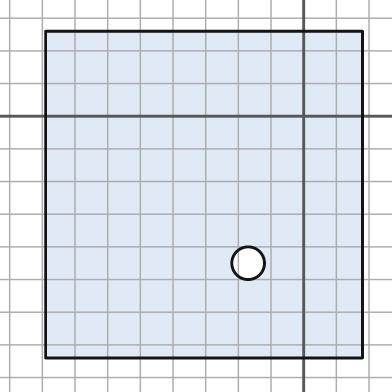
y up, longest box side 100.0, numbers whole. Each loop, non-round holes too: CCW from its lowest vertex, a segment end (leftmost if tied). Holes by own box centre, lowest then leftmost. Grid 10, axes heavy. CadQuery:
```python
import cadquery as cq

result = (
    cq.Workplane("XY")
    .moveTo(-79.0, -74.0)
    .lineTo(18.0, -74.0)
    .lineTo(18.0, 26.0)
    .lineTo(-79.0, 26.0)
    .close()
    .moveTo(-17.0, -45.0)
    .circle(5.0)
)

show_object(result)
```